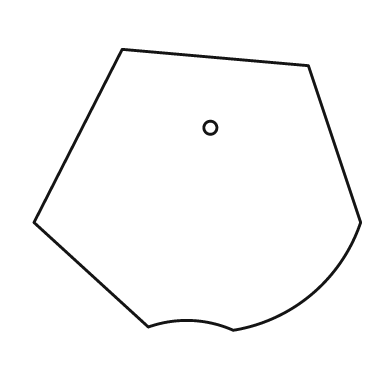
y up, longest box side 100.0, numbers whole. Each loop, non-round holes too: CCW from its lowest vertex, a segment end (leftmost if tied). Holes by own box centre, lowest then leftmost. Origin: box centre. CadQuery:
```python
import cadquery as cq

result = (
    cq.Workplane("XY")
    .moveTo(11.0, -43.0)
    .threePointArc((35.0, -32.0), (50.0, -10.0))
    .lineTo(34.0, 38.0)
    .lineTo(-23.0, 43.0)
    .lineTo(-50.0, -10.0)
    .lineTo(-15.0, -42.0)
    .threePointArc((-2.0, -40.0), (11.0, -43.0))
    .close()
    .moveTo(4.0, 19.0)
    .circle(2.0)
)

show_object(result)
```